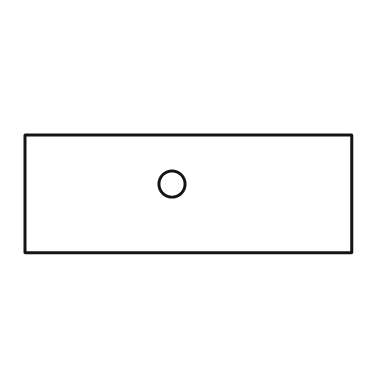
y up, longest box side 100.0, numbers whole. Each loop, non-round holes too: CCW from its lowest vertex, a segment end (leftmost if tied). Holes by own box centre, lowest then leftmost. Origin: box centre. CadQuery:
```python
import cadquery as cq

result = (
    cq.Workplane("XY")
    .moveTo(-50.0, -18.0)
    .lineTo(50.0, -18.0)
    .lineTo(50.0, 18.0)
    .lineTo(-50.0, 18.0)
    .close()
    .moveTo(-5.0, 3.0)
    .circle(4.0)
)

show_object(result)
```